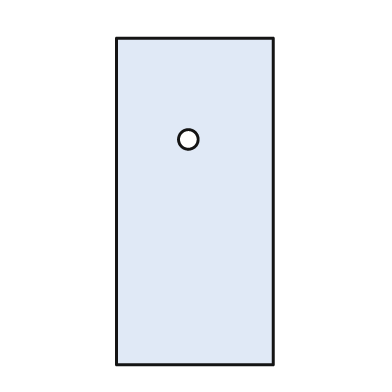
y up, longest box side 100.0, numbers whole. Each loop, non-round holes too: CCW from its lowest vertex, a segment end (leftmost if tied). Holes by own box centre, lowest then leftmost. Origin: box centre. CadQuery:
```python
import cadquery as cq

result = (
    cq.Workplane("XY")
    .moveTo(-24.0, -50.0)
    .lineTo(24.0, -50.0)
    .lineTo(24.0, 50.0)
    .lineTo(-24.0, 50.0)
    .close()
    .moveTo(-2.0, 19.0)
    .circle(3.0)
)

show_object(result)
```